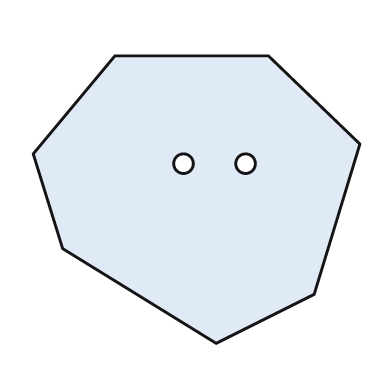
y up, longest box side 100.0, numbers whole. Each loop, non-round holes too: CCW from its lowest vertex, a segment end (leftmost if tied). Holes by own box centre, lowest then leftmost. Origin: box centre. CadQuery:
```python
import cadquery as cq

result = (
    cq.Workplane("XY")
    .moveTo(6.0, -44.0)
    .lineTo(36.0, -29.0)
    .lineTo(50.0, 17.0)
    .lineTo(22.0, 44.0)
    .lineTo(-25.0, 44.0)
    .lineTo(-50.0, 14.0)
    .lineTo(-41.0, -15.0)
    .close()
    .moveTo(-4.0, 11.0)
    .circle(3.0)
    .moveTo(15.0, 11.0)
    .circle(3.0)
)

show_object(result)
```